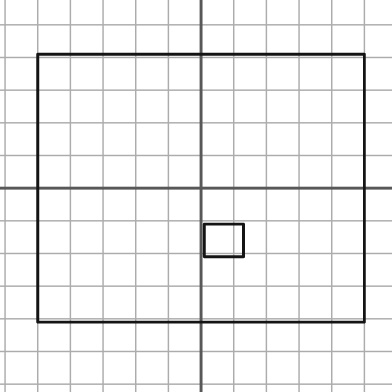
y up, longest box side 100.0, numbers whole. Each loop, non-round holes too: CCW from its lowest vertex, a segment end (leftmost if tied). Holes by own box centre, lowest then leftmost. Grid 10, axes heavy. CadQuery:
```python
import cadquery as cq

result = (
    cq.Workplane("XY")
    .moveTo(-50.0, -41.0)
    .lineTo(50.0, -41.0)
    .lineTo(50.0, 41.0)
    .lineTo(-50.0, 41.0)
    .close()
    .moveTo(1.0, -21.0)
    .lineTo(13.0, -21.0)
    .lineTo(13.0, -11.0)
    .lineTo(1.0, -11.0)
    .close()
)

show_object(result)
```